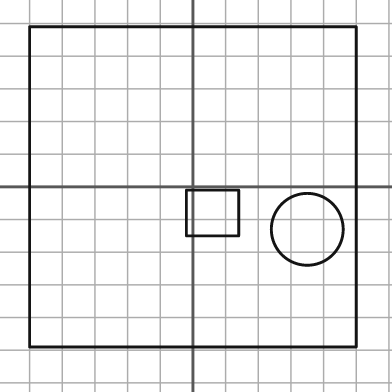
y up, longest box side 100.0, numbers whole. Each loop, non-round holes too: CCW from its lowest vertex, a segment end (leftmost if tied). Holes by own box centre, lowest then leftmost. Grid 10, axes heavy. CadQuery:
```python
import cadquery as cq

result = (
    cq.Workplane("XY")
    .moveTo(-50.0, -49.0)
    .lineTo(50.0, -49.0)
    .lineTo(50.0, 49.0)
    .lineTo(-50.0, 49.0)
    .close()
    .moveTo(35.0, -13.0)
    .circle(11.0)
    .moveTo(-2.0, -15.0)
    .lineTo(14.0, -15.0)
    .lineTo(14.0, -1.0)
    .lineTo(-2.0, -1.0)
    .close()
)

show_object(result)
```